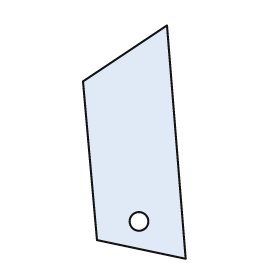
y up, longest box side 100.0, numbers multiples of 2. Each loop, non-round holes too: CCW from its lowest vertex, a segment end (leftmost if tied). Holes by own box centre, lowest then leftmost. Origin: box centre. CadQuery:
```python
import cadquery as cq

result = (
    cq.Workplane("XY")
    .moveTo(22.0, -50.0)
    .lineTo(14.0, 50.0)
    .lineTo(-22.0, 26.0)
    .lineTo(-16.0, -42.0)
    .close()
    .moveTo(2.0, -34.0)
    .circle(4.0)
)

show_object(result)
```